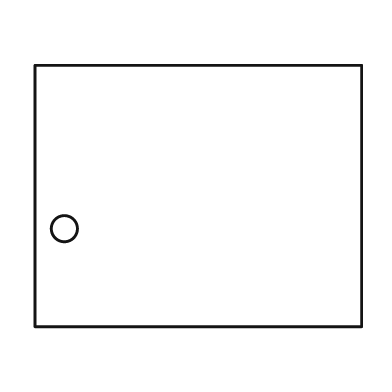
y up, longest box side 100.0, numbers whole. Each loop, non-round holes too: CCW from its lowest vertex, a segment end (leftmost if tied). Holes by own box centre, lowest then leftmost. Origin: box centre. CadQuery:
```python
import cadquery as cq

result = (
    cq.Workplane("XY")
    .moveTo(-50.0, -40.0)
    .lineTo(50.0, -40.0)
    .lineTo(50.0, 40.0)
    .lineTo(-50.0, 40.0)
    .close()
    .moveTo(-41.0, -10.0)
    .circle(4.0)
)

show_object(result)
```